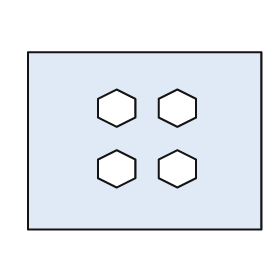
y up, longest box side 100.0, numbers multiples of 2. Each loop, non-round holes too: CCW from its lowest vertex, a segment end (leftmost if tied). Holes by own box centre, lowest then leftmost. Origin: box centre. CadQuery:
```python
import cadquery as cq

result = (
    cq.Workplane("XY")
    .moveTo(-50.0, -38.0)
    .lineTo(50.0, -38.0)
    .lineTo(50.0, 38.0)
    .lineTo(-50.0, 38.0)
    .close()
    .moveTo(-12.0, -20.0)
    .lineTo(-4.0, -16.0)
    .lineTo(-4.0, -8.0)
    .lineTo(-12.0, -4.0)
    .lineTo(-20.0, -8.0)
    .lineTo(-20.0, -16.0)
    .close()
    .moveTo(14.0, -20.0)
    .lineTo(22.0, -16.0)
    .lineTo(22.0, -8.0)
    .lineTo(14.0, -4.0)
    .lineTo(6.0, -8.0)
    .lineTo(6.0, -16.0)
    .close()
    .moveTo(-12.0, 6.0)
    .lineTo(-4.0, 10.0)
    .lineTo(-4.0, 18.0)
    .lineTo(-12.0, 22.0)
    .lineTo(-20.0, 18.0)
    .lineTo(-20.0, 10.0)
    .close()
    .moveTo(14.0, 6.0)
    .lineTo(22.0, 10.0)
    .lineTo(22.0, 18.0)
    .lineTo(14.0, 22.0)
    .lineTo(6.0, 18.0)
    .lineTo(6.0, 10.0)
    .close()
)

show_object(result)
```